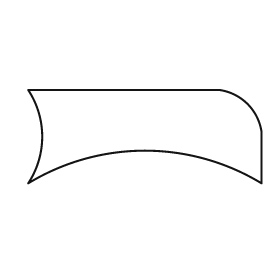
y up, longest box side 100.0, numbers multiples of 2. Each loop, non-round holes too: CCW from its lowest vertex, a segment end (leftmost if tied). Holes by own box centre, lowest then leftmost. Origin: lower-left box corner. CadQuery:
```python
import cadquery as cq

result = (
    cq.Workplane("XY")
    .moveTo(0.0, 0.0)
    .threePointArc((50.0, 14.0), (100.0, 0.0))
    .lineTo(100.0, 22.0)
    .threePointArc((94.0, 34.0), (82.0, 40.0))
    .lineTo(0.0, 40.0)
    .threePointArc((6.0, 20.0), (0.0, 0.0))
    .close()
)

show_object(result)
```